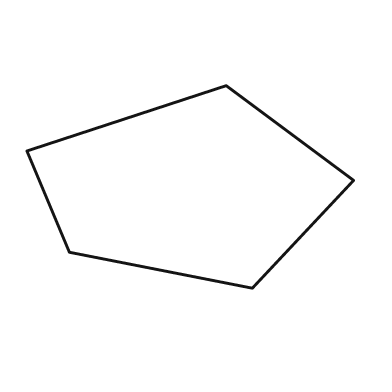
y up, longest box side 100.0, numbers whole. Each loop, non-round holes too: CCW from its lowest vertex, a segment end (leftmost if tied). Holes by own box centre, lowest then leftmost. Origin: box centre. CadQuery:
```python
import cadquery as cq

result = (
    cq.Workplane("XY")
    .moveTo(19.0, -31.0)
    .lineTo(50.0, 2.0)
    .lineTo(11.0, 31.0)
    .lineTo(-50.0, 11.0)
    .lineTo(-37.0, -20.0)
    .close()
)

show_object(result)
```